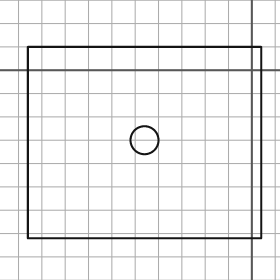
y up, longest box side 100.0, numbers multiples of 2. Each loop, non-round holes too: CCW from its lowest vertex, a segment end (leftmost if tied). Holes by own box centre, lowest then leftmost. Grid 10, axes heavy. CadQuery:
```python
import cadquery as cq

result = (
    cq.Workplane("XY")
    .moveTo(-96.0, -72.0)
    .lineTo(4.0, -72.0)
    .lineTo(4.0, 10.0)
    .lineTo(-96.0, 10.0)
    .close()
    .moveTo(-46.0, -30.0)
    .circle(6.0)
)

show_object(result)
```